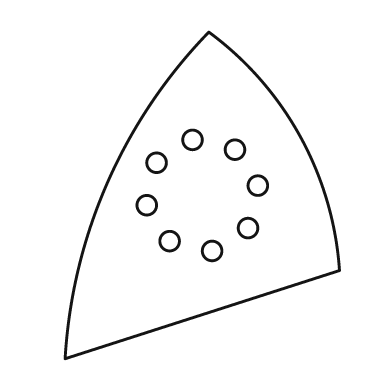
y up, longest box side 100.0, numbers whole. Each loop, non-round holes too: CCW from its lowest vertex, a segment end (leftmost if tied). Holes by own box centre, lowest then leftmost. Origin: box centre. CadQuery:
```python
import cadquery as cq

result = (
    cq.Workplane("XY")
    .moveTo(-42.0, -50.0)
    .lineTo(42.0, -23.0)
    .threePointArc((30.0, 18.0), (2.0, 50.0))
    .threePointArc((-29.0, 4.0), (-42.0, -50.0))
    .close()
    .moveTo(3.0, -17.0)
    .circle(3.0)
    .moveTo(-10.0, -14.0)
    .circle(3.0)
    .moveTo(14.0, -10.0)
    .circle(3.0)
    .moveTo(-17.0, -3.0)
    .circle(3.0)
    .moveTo(17.0, 3.0)
    .circle(3.0)
    .moveTo(-14.0, 10.0)
    .circle(3.0)
    .moveTo(10.0, 14.0)
    .circle(3.0)
    .moveTo(-3.0, 17.0)
    .circle(3.0)
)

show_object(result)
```